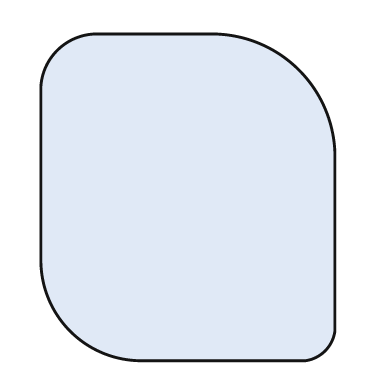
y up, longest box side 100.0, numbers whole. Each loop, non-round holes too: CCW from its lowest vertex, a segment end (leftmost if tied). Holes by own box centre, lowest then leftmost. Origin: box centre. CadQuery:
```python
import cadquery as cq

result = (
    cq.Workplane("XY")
    .moveTo(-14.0, -50.0)
    .lineTo(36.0, -50.0)
    .threePointArc((42.0, -47.0), (45.0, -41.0))
    .lineTo(45.0, 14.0)
    .threePointArc((34.0, 39.0), (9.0, 50.0))
    .lineTo(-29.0, 50.0)
    .threePointArc((-40.0, 45.0), (-45.0, 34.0))
    .lineTo(-45.0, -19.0)
    .threePointArc((-36.0, -41.0), (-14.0, -50.0))
    .close()
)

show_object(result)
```